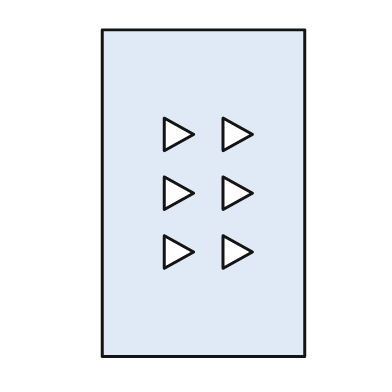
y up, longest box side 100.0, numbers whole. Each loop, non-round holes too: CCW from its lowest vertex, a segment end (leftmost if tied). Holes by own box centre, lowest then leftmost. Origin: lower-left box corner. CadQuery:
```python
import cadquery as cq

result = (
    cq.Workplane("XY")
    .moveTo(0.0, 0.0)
    .lineTo(62.0, 0.0)
    .lineTo(62.0, 100.0)
    .lineTo(0.0, 100.0)
    .close()
    .moveTo(19.0, 27.0)
    .lineTo(28.0, 32.0)
    .lineTo(19.0, 37.0)
    .close()
    .moveTo(37.0, 27.0)
    .lineTo(46.0, 32.0)
    .lineTo(37.0, 37.0)
    .close()
    .moveTo(19.0, 45.0)
    .lineTo(28.0, 50.0)
    .lineTo(19.0, 55.0)
    .close()
    .moveTo(37.0, 45.0)
    .lineTo(46.0, 50.0)
    .lineTo(37.0, 55.0)
    .close()
    .moveTo(19.0, 63.0)
    .lineTo(28.0, 68.0)
    .lineTo(19.0, 73.0)
    .close()
    .moveTo(37.0, 63.0)
    .lineTo(46.0, 68.0)
    .lineTo(37.0, 73.0)
    .close()
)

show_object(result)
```